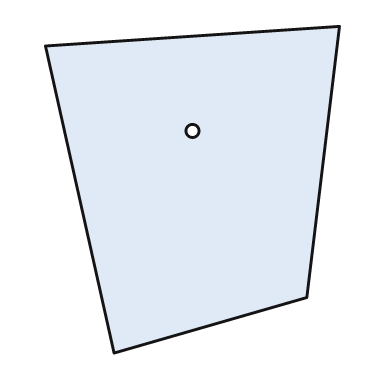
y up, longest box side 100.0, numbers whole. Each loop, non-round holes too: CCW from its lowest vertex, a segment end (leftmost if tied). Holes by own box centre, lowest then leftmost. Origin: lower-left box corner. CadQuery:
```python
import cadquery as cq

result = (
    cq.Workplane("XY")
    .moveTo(21.0, 0.0)
    .lineTo(80.0, 17.0)
    .lineTo(90.0, 100.0)
    .lineTo(0.0, 94.0)
    .close()
    .moveTo(45.0, 68.0)
    .circle(2.0)
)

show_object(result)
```